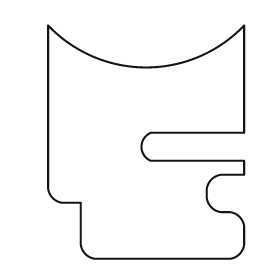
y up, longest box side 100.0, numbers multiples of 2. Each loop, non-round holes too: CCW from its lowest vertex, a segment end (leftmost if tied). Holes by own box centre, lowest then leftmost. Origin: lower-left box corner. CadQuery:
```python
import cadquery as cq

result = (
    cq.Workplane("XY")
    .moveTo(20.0, 0.0)
    .lineTo(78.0, 0.0)
    .threePointArc((82.0, 2.0), (84.0, 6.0))
    .lineTo(84.0, 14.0)
    .threePointArc((82.0, 18.0), (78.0, 20.0))
    .lineTo(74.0, 20.0)
    .threePointArc((70.0, 22.0), (68.0, 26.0))
    .lineTo(68.0, 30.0)
    .threePointArc((70.0, 34.0), (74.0, 36.0))
    .lineTo(84.0, 36.0)
    .lineTo(84.0, 42.0)
    .lineTo(44.0, 42.0)
    .threePointArc((40.0, 48.0), (44.0, 54.0))
    .lineTo(84.0, 54.0)
    .lineTo(84.0, 100.0)
    .threePointArc((42.0, 82.0), (0.0, 100.0))
    .lineTo(0.0, 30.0)
    .threePointArc((2.0, 26.0), (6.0, 24.0))
    .lineTo(14.0, 24.0)
    .lineTo(14.0, 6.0)
    .threePointArc((16.0, 2.0), (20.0, 0.0))
    .close()
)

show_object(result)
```